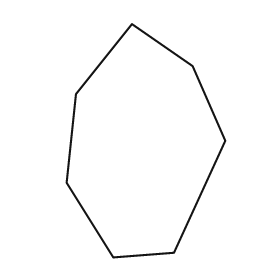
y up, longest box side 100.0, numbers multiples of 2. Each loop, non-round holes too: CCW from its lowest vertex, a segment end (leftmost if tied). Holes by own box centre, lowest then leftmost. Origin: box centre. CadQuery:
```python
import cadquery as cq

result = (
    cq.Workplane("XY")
    .moveTo(-14.0, -50.0)
    .lineTo(12.0, -48.0)
    .lineTo(34.0, 0.0)
    .lineTo(20.0, 32.0)
    .lineTo(-6.0, 50.0)
    .lineTo(-30.0, 20.0)
    .lineTo(-34.0, -18.0)
    .close()
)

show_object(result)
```